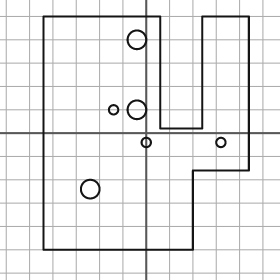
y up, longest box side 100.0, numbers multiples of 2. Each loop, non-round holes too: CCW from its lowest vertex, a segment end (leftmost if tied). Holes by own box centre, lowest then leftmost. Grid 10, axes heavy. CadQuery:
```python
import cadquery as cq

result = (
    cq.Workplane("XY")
    .moveTo(-44.0, -50.0)
    .lineTo(20.0, -50.0)
    .lineTo(20.0, -16.0)
    .lineTo(44.0, -16.0)
    .lineTo(44.0, 50.0)
    .lineTo(24.0, 50.0)
    .lineTo(24.0, 2.0)
    .lineTo(6.0, 2.0)
    .lineTo(6.0, 50.0)
    .lineTo(-44.0, 50.0)
    .close()
    .moveTo(-24.0, -24.0)
    .circle(4.0)
    .moveTo(0.0, -4.0)
    .circle(2.0)
    .moveTo(32.0, -4.0)
    .circle(2.0)
    .moveTo(-14.0, 10.0)
    .circle(2.0)
    .moveTo(-4.0, 10.0)
    .circle(4.0)
    .moveTo(-4.0, 40.0)
    .circle(4.0)
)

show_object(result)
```